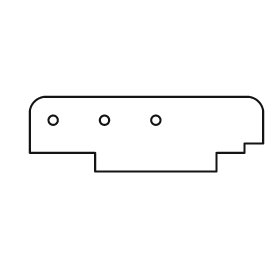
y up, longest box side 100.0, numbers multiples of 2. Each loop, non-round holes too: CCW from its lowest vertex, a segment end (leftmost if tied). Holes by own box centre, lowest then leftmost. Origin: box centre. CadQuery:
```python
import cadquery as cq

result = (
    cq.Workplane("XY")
    .moveTo(-22.0, -16.0)
    .lineTo(30.0, -16.0)
    .lineTo(30.0, -8.0)
    .lineTo(42.0, -8.0)
    .lineTo(42.0, -4.0)
    .lineTo(50.0, -4.0)
    .lineTo(50.0, 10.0)
    .threePointArc((48.0, 14.0), (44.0, 16.0))
    .lineTo(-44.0, 16.0)
    .threePointArc((-48.0, 14.0), (-50.0, 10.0))
    .lineTo(-50.0, -8.0)
    .lineTo(-22.0, -8.0)
    .close()
    .moveTo(-40.0, 6.0)
    .circle(2.0)
    .moveTo(-18.0, 6.0)
    .circle(2.0)
    .moveTo(4.0, 6.0)
    .circle(2.0)
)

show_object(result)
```